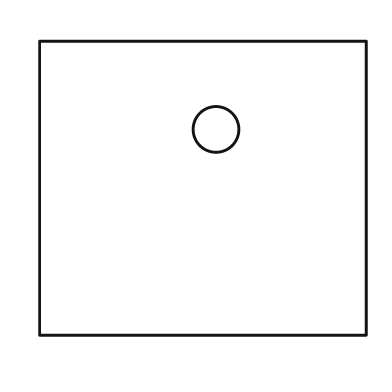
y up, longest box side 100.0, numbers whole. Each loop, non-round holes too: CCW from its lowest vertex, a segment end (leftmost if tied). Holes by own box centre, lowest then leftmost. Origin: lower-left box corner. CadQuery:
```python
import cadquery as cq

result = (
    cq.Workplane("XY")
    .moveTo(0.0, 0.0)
    .lineTo(100.0, 0.0)
    .lineTo(100.0, 90.0)
    .lineTo(0.0, 90.0)
    .close()
    .moveTo(54.0, 63.0)
    .circle(7.0)
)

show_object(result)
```